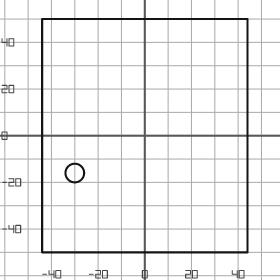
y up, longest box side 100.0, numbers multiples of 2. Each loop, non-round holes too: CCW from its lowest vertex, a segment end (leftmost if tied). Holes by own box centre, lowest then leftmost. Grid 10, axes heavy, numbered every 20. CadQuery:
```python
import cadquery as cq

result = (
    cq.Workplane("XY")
    .moveTo(-44.0, -50.0)
    .lineTo(44.0, -50.0)
    .lineTo(44.0, 50.0)
    .lineTo(-44.0, 50.0)
    .close()
    .moveTo(-30.0, -16.0)
    .circle(4.0)
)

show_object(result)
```